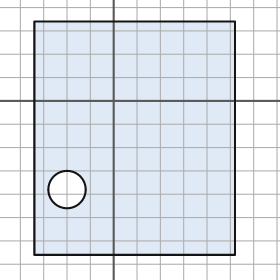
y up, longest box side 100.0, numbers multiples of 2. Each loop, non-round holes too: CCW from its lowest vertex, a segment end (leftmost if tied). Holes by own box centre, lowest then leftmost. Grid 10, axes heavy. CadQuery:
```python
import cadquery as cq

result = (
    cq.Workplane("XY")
    .moveTo(-34.0, -66.0)
    .lineTo(52.0, -66.0)
    .lineTo(52.0, 34.0)
    .lineTo(-34.0, 34.0)
    .close()
    .moveTo(-20.0, -38.0)
    .circle(8.0)
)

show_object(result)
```